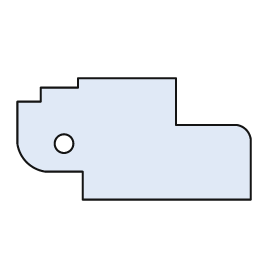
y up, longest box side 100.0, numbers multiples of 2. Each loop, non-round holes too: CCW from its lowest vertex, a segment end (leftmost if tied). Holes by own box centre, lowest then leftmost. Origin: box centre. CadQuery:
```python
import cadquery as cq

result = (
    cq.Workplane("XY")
    .moveTo(-22.0, -26.0)
    .lineTo(50.0, -26.0)
    .lineTo(50.0, 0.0)
    .threePointArc((48.0, 4.0), (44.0, 6.0))
    .lineTo(18.0, 6.0)
    .lineTo(18.0, 26.0)
    .lineTo(-24.0, 26.0)
    .lineTo(-24.0, 22.0)
    .lineTo(-40.0, 22.0)
    .lineTo(-40.0, 16.0)
    .lineTo(-50.0, 16.0)
    .lineTo(-50.0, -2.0)
    .threePointArc((-46.0, -10.0), (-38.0, -14.0))
    .lineTo(-22.0, -14.0)
    .close()
    .moveTo(-30.0, -2.0)
    .circle(4.0)
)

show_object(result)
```